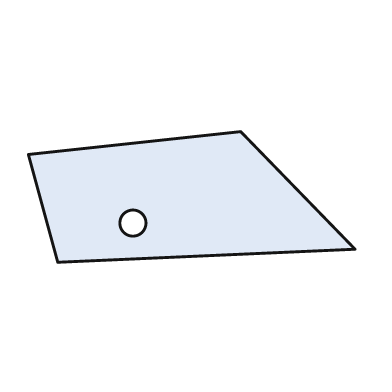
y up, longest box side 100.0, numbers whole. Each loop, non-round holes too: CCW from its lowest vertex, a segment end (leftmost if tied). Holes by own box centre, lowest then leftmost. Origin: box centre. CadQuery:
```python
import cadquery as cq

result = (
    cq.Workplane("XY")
    .moveTo(-41.0, -20.0)
    .lineTo(50.0, -16.0)
    .lineTo(15.0, 20.0)
    .lineTo(-50.0, 13.0)
    .close()
    .moveTo(-18.0, -8.0)
    .circle(4.0)
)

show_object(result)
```